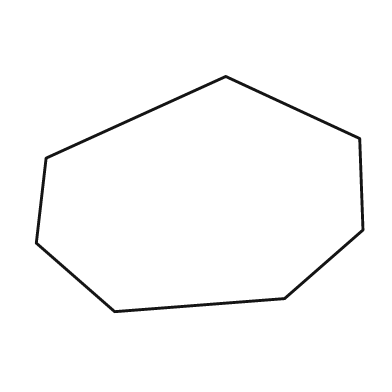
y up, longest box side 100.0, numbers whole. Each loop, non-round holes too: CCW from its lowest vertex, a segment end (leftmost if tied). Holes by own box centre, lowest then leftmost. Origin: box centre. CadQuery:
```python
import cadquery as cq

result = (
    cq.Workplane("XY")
    .moveTo(-26.0, -36.0)
    .lineTo(26.0, -32.0)
    .lineTo(50.0, -11.0)
    .lineTo(49.0, 17.0)
    .lineTo(8.0, 36.0)
    .lineTo(-47.0, 11.0)
    .lineTo(-50.0, -15.0)
    .close()
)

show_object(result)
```